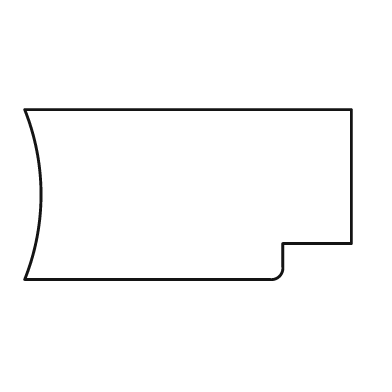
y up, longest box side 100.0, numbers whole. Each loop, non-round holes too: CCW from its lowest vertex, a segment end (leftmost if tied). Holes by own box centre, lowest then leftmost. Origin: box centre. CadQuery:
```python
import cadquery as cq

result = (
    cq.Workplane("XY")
    .moveTo(-50.0, -26.0)
    .lineTo(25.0, -26.0)
    .threePointArc((28.0, -25.0), (29.0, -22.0))
    .lineTo(29.0, -15.0)
    .lineTo(50.0, -15.0)
    .lineTo(50.0, 26.0)
    .lineTo(-50.0, 26.0)
    .threePointArc((-45.0, 0.0), (-50.0, -26.0))
    .close()
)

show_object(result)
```